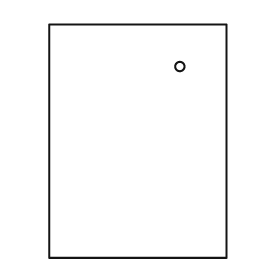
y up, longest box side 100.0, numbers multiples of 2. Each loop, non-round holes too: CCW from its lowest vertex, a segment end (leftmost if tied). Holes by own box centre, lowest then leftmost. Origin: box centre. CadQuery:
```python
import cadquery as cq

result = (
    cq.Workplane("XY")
    .moveTo(-38.0, -50.0)
    .lineTo(38.0, -50.0)
    .lineTo(38.0, 50.0)
    .lineTo(-38.0, 50.0)
    .close()
    .moveTo(18.0, 32.0)
    .circle(2.0)
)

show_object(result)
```